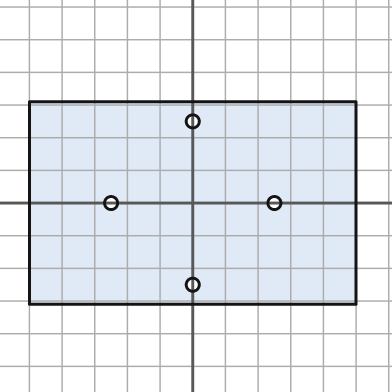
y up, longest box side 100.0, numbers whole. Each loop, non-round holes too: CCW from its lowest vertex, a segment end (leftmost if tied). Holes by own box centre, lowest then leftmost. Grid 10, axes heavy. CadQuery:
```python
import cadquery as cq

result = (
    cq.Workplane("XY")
    .moveTo(-50.0, -31.0)
    .lineTo(50.0, -31.0)
    .lineTo(50.0, 31.0)
    .lineTo(-50.0, 31.0)
    .close()
    .moveTo(0.0, -25.0)
    .circle(2.0)
    .moveTo(-25.0, 0.0)
    .circle(2.0)
    .moveTo(25.0, 0.0)
    .circle(2.0)
    .moveTo(0.0, 25.0)
    .circle(2.0)
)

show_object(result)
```